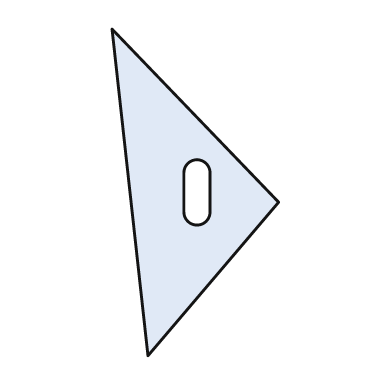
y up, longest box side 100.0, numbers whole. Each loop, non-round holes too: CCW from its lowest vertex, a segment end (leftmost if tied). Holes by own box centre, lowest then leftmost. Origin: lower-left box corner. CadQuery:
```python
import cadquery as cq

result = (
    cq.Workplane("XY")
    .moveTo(11.0, 0.0)
    .lineTo(51.0, 47.0)
    .lineTo(0.0, 100.0)
    .close()
    .moveTo(22.0, 44.0)
    .threePointArc((26.0, 40.0), (30.0, 44.0))
    .lineTo(30.0, 56.0)
    .threePointArc((26.0, 60.0), (22.0, 56.0))
    .close()
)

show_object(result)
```